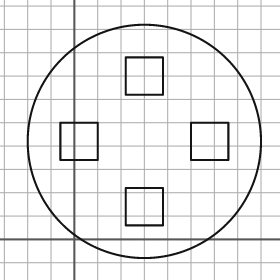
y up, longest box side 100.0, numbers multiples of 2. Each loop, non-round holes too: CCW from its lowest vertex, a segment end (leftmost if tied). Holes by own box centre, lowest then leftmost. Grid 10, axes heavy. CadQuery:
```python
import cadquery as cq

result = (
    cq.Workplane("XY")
    .moveTo(30.0, 42.0)
    .circle(50.0)
    .moveTo(22.0, 6.0)
    .lineTo(38.0, 6.0)
    .lineTo(38.0, 22.0)
    .lineTo(22.0, 22.0)
    .close()
    .moveTo(-6.0, 34.0)
    .lineTo(10.0, 34.0)
    .lineTo(10.0, 50.0)
    .lineTo(-6.0, 50.0)
    .close()
    .moveTo(50.0, 34.0)
    .lineTo(66.0, 34.0)
    .lineTo(66.0, 50.0)
    .lineTo(50.0, 50.0)
    .close()
    .moveTo(22.0, 62.0)
    .lineTo(38.0, 62.0)
    .lineTo(38.0, 78.0)
    .lineTo(22.0, 78.0)
    .close()
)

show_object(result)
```